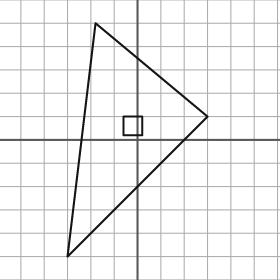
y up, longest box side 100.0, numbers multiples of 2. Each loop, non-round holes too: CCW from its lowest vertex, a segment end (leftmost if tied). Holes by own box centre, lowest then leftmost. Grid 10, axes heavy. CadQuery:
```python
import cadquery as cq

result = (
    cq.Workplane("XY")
    .moveTo(-30.0, -50.0)
    .lineTo(30.0, 10.0)
    .lineTo(-18.0, 50.0)
    .close()
    .moveTo(-6.0, 2.0)
    .lineTo(2.0, 2.0)
    .lineTo(2.0, 10.0)
    .lineTo(-6.0, 10.0)
    .close()
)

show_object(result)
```